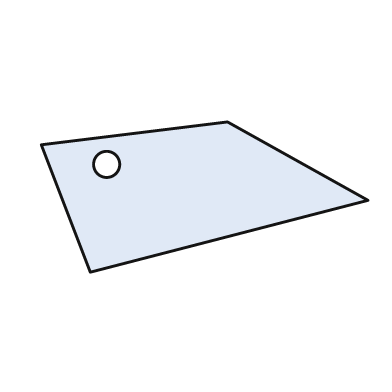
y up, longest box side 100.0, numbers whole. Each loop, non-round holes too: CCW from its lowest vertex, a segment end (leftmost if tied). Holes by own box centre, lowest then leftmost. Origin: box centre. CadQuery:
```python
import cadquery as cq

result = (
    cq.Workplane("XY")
    .moveTo(-35.0, -23.0)
    .lineTo(50.0, -1.0)
    .lineTo(7.0, 23.0)
    .lineTo(-50.0, 16.0)
    .close()
    .moveTo(-30.0, 10.0)
    .circle(4.0)
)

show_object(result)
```